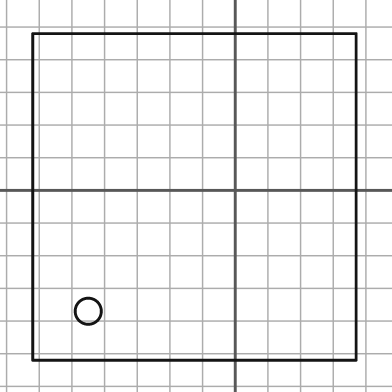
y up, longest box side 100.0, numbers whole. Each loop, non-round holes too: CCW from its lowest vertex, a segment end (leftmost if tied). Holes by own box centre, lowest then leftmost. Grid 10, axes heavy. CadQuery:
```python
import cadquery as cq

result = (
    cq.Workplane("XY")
    .moveTo(-62.0, -52.0)
    .lineTo(37.0, -52.0)
    .lineTo(37.0, 48.0)
    .lineTo(-62.0, 48.0)
    .close()
    .moveTo(-45.0, -37.0)
    .circle(4.0)
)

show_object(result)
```